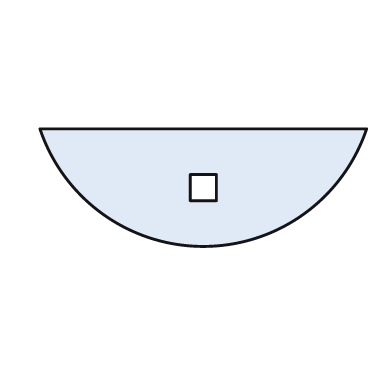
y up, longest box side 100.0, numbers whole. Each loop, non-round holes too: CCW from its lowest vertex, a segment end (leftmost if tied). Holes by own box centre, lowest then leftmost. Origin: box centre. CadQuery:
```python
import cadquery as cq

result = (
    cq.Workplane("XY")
    .moveTo(-50.0, 18.0)
    .threePointArc((0.0, -18.0), (50.0, 18.0))
    .close()
    .moveTo(-4.0, -4.0)
    .lineTo(4.0, -4.0)
    .lineTo(4.0, 4.0)
    .lineTo(-4.0, 4.0)
    .close()
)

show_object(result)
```